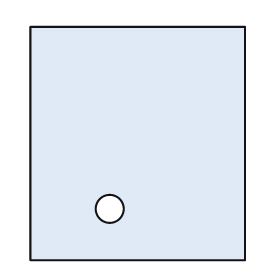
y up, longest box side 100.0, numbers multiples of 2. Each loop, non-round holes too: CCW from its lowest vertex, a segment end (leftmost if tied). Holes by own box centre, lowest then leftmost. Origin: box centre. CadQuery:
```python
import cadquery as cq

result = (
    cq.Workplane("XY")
    .moveTo(-46.0, -50.0)
    .lineTo(46.0, -50.0)
    .lineTo(46.0, 50.0)
    .lineTo(-46.0, 50.0)
    .close()
    .moveTo(-12.0, -28.0)
    .circle(6.0)
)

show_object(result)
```